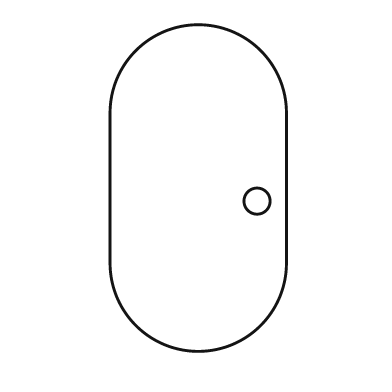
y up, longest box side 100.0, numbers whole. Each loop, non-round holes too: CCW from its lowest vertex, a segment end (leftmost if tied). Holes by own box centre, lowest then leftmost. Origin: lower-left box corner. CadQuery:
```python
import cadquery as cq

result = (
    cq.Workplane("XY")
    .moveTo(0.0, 27.0)
    .threePointArc((27.0, 0.0), (54.0, 27.0))
    .lineTo(54.0, 73.0)
    .threePointArc((27.0, 100.0), (0.0, 73.0))
    .close()
    .moveTo(45.0, 46.0)
    .circle(4.0)
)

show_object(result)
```